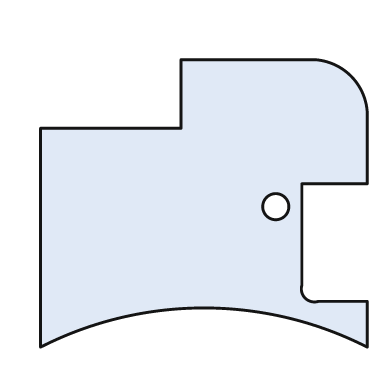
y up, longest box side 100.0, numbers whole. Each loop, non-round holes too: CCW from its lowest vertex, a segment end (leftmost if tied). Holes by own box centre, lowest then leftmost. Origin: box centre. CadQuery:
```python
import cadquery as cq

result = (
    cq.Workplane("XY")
    .moveTo(-50.0, -44.0)
    .threePointArc((0.0, -32.0), (50.0, -44.0))
    .lineTo(50.0, -30.0)
    .lineTo(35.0, -30.0)
    .threePointArc((31.0, -29.0), (30.0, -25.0))
    .lineTo(30.0, 6.0)
    .lineTo(50.0, 6.0)
    .lineTo(50.0, 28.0)
    .threePointArc((45.0, 39.0), (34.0, 44.0))
    .lineTo(-7.0, 44.0)
    .lineTo(-7.0, 23.0)
    .lineTo(-50.0, 23.0)
    .close()
    .moveTo(22.0, -1.0)
    .circle(4.0)
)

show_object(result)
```